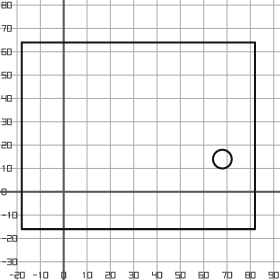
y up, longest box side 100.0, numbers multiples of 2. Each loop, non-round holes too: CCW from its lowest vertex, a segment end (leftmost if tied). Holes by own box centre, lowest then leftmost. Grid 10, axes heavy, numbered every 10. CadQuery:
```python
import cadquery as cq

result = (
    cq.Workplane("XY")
    .moveTo(-18.0, -16.0)
    .lineTo(82.0, -16.0)
    .lineTo(82.0, 64.0)
    .lineTo(-18.0, 64.0)
    .close()
    .moveTo(68.0, 14.0)
    .circle(4.0)
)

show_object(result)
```